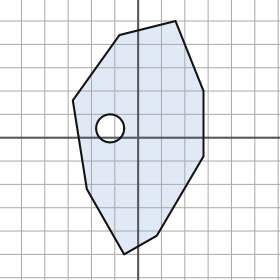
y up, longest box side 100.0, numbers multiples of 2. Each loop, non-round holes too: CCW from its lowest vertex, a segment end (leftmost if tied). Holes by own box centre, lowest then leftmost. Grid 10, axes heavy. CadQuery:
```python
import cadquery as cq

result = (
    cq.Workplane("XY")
    .moveTo(-6.0, -50.0)
    .lineTo(8.0, -42.0)
    .lineTo(28.0, -8.0)
    .lineTo(28.0, 20.0)
    .lineTo(16.0, 50.0)
    .lineTo(-8.0, 44.0)
    .lineTo(-28.0, 16.0)
    .lineTo(-22.0, -22.0)
    .close()
    .moveTo(-12.0, 4.0)
    .circle(6.0)
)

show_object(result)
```